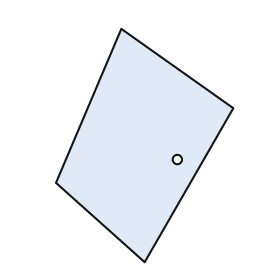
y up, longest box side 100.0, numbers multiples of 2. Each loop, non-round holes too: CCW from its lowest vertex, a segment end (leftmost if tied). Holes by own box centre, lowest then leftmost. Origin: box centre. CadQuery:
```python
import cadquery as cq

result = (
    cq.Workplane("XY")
    .moveTo(0.0, -50.0)
    .lineTo(38.0, 16.0)
    .lineTo(-10.0, 50.0)
    .lineTo(-38.0, -16.0)
    .close()
    .moveTo(14.0, -6.0)
    .circle(2.0)
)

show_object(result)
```